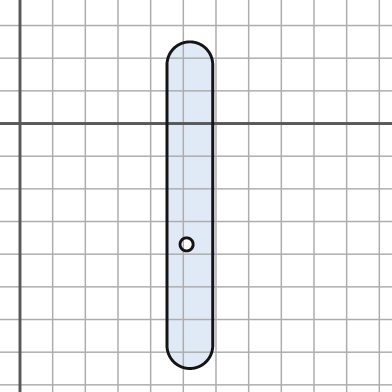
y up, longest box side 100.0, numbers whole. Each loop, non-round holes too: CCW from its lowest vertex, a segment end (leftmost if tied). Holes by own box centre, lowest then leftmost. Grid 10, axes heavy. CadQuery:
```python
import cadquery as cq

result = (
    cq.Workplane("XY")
    .moveTo(45.0, -68.0)
    .threePointArc((52.0, -75.0), (59.0, -68.0))
    .lineTo(59.0, 18.0)
    .threePointArc((52.0, 25.0), (45.0, 18.0))
    .close()
    .moveTo(51.0, -37.0)
    .circle(2.0)
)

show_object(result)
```